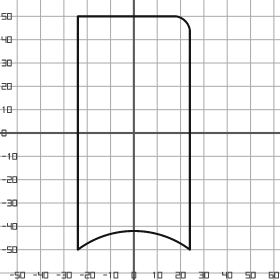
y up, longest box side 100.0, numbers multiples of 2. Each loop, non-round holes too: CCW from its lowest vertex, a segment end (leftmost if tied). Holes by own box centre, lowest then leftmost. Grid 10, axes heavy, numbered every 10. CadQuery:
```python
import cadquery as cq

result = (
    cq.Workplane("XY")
    .moveTo(-24.0, -50.0)
    .threePointArc((0.0, -42.0), (24.0, -50.0))
    .lineTo(24.0, 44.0)
    .threePointArc((22.0, 48.0), (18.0, 50.0))
    .lineTo(-24.0, 50.0)
    .close()
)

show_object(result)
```